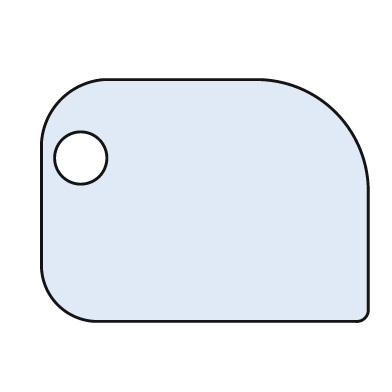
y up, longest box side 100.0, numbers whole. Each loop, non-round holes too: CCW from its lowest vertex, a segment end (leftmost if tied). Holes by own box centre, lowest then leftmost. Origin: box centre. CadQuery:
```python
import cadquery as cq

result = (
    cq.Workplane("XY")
    .moveTo(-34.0, -37.0)
    .lineTo(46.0, -37.0)
    .threePointArc((49.0, -36.0), (50.0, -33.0))
    .lineTo(50.0, 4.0)
    .threePointArc((40.0, 27.0), (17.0, 37.0))
    .lineTo(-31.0, 37.0)
    .threePointArc((-44.0, 31.0), (-50.0, 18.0))
    .lineTo(-50.0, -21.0)
    .threePointArc((-45.0, -32.0), (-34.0, -37.0))
    .close()
    .moveTo(-38.0, 13.0)
    .circle(8.0)
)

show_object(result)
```